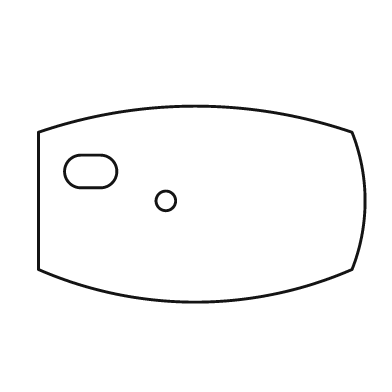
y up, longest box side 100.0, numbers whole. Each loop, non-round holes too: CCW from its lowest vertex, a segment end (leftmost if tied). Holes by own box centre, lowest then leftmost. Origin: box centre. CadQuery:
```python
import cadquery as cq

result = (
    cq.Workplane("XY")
    .moveTo(-50.0, -20.0)
    .threePointArc((-2.0, -30.0), (46.0, -20.0))
    .threePointArc((50.0, 1.0), (46.0, 22.0))
    .threePointArc((-2.0, 30.0), (-50.0, 22.0))
    .close()
    .moveTo(-11.0, 1.0)
    .circle(3.0)
    .moveTo(-37.0, 5.0)
    .lineTo(-31.0, 5.0)
    .threePointArc((-26.0, 10.0), (-31.0, 15.0))
    .lineTo(-37.0, 15.0)
    .threePointArc((-42.0, 10.0), (-37.0, 5.0))
    .close()
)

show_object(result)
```